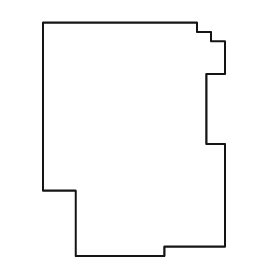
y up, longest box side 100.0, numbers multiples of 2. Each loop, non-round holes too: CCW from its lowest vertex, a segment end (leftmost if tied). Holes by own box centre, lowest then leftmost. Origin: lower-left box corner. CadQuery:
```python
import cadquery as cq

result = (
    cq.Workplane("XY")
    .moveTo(14.0, 0.0)
    .lineTo(52.0, 0.0)
    .lineTo(52.0, 4.0)
    .lineTo(78.0, 4.0)
    .lineTo(78.0, 48.0)
    .lineTo(70.0, 48.0)
    .lineTo(70.0, 78.0)
    .lineTo(78.0, 78.0)
    .lineTo(78.0, 92.0)
    .lineTo(72.0, 92.0)
    .lineTo(72.0, 96.0)
    .lineTo(66.0, 96.0)
    .lineTo(66.0, 100.0)
    .lineTo(0.0, 100.0)
    .lineTo(0.0, 28.0)
    .lineTo(14.0, 28.0)
    .close()
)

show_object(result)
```